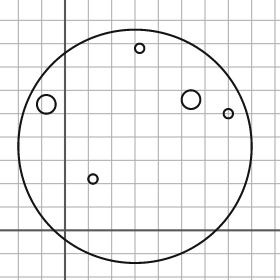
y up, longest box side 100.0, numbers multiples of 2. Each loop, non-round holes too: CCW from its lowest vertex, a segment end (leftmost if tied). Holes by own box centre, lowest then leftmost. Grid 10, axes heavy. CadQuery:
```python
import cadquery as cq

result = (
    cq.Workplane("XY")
    .moveTo(30.0, 36.0)
    .circle(50.0)
    .moveTo(12.0, 22.0)
    .circle(2.0)
    .moveTo(70.0, 50.0)
    .circle(2.0)
    .moveTo(-8.0, 54.0)
    .circle(4.0)
    .moveTo(54.0, 56.0)
    .circle(4.0)
    .moveTo(32.0, 78.0)
    .circle(2.0)
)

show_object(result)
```